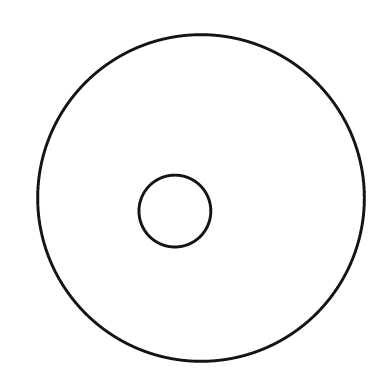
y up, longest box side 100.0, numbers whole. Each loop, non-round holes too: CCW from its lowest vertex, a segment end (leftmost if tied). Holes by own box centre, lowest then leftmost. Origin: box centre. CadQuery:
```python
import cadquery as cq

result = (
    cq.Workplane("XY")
    .moveTo(0.0, 0.0)
    .circle(50.0)
    .moveTo(-8.0, -4.0)
    .circle(11.0)
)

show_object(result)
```